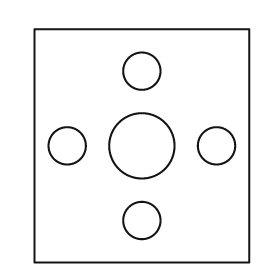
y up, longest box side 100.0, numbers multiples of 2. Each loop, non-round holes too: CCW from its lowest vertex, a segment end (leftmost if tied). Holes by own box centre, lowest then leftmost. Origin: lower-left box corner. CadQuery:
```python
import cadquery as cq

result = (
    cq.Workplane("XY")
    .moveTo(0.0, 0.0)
    .lineTo(92.0, 0.0)
    .lineTo(92.0, 100.0)
    .lineTo(0.0, 100.0)
    .close()
    .moveTo(46.0, 18.0)
    .circle(8.0)
    .moveTo(14.0, 50.0)
    .circle(8.0)
    .moveTo(46.0, 50.0)
    .circle(14.0)
    .moveTo(78.0, 50.0)
    .circle(8.0)
    .moveTo(46.0, 82.0)
    .circle(8.0)
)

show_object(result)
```